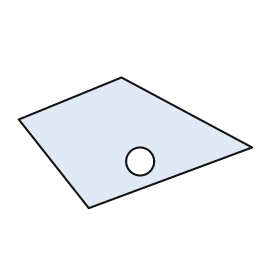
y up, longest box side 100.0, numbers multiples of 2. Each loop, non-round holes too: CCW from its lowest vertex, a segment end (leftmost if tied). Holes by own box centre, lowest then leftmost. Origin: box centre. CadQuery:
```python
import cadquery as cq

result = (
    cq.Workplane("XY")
    .moveTo(-20.0, -28.0)
    .lineTo(50.0, -2.0)
    .lineTo(-6.0, 28.0)
    .lineTo(-50.0, 10.0)
    .close()
    .moveTo(2.0, -8.0)
    .circle(6.0)
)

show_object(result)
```